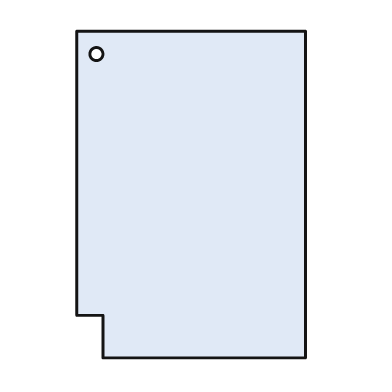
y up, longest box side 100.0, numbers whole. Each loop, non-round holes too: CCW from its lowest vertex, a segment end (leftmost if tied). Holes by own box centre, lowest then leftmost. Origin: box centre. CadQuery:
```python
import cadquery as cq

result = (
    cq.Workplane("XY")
    .moveTo(-27.0, -50.0)
    .lineTo(35.0, -50.0)
    .lineTo(35.0, 50.0)
    .lineTo(-35.0, 50.0)
    .lineTo(-35.0, -37.0)
    .lineTo(-27.0, -37.0)
    .close()
    .moveTo(-29.0, 43.0)
    .circle(2.0)
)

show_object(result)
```